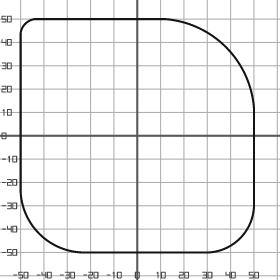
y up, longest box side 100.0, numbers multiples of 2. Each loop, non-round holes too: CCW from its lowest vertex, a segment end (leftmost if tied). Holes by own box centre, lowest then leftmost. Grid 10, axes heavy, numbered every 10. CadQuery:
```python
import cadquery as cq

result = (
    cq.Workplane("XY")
    .moveTo(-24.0, -50.0)
    .lineTo(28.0, -50.0)
    .threePointArc((44.0, -44.0), (50.0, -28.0))
    .lineTo(50.0, 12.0)
    .threePointArc((38.0, 38.0), (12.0, 50.0))
    .lineTo(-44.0, 50.0)
    .threePointArc((-48.0, 48.0), (-50.0, 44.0))
    .lineTo(-50.0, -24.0)
    .threePointArc((-42.0, -42.0), (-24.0, -50.0))
    .close()
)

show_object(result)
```